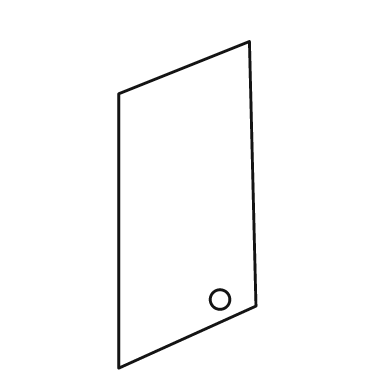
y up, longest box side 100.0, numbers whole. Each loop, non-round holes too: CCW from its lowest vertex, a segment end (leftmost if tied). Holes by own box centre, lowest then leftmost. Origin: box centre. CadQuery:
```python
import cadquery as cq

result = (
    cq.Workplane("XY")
    .moveTo(-21.0, -50.0)
    .lineTo(21.0, -31.0)
    .lineTo(19.0, 50.0)
    .lineTo(-21.0, 34.0)
    .close()
    .moveTo(10.0, -29.0)
    .circle(3.0)
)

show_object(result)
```